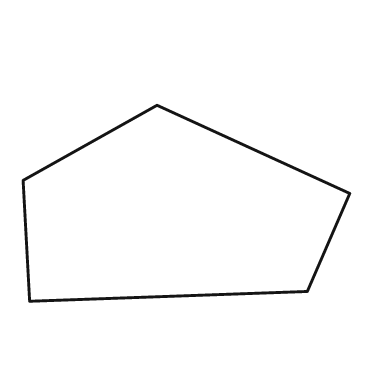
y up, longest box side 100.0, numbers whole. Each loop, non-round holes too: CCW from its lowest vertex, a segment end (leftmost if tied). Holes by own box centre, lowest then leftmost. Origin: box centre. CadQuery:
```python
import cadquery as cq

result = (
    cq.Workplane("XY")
    .moveTo(-48.0, -30.0)
    .lineTo(37.0, -27.0)
    .lineTo(50.0, 3.0)
    .lineTo(-9.0, 30.0)
    .lineTo(-50.0, 7.0)
    .close()
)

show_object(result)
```